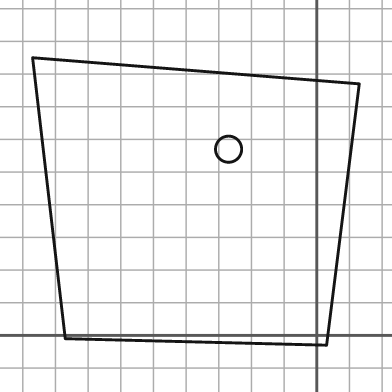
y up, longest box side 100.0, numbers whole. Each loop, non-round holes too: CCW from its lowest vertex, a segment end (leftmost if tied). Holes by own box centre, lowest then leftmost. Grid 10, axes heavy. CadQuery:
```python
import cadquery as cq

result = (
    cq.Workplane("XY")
    .moveTo(3.0, -3.0)
    .lineTo(13.0, 77.0)
    .lineTo(-87.0, 85.0)
    .lineTo(-77.0, -1.0)
    .close()
    .moveTo(-27.0, 57.0)
    .circle(4.0)
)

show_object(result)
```